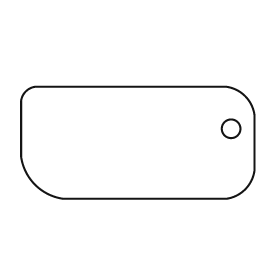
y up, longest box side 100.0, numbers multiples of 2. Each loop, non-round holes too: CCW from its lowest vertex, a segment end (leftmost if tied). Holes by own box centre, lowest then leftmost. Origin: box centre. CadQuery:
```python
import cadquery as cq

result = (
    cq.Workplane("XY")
    .moveTo(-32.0, -24.0)
    .lineTo(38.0, -24.0)
    .threePointArc((46.0, -20.0), (50.0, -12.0))
    .lineTo(50.0, 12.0)
    .threePointArc((46.0, 20.0), (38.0, 24.0))
    .lineTo(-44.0, 24.0)
    .threePointArc((-48.0, 22.0), (-50.0, 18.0))
    .lineTo(-50.0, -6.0)
    .threePointArc((-44.0, -18.0), (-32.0, -24.0))
    .close()
    .moveTo(40.0, 6.0)
    .circle(4.0)
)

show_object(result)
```